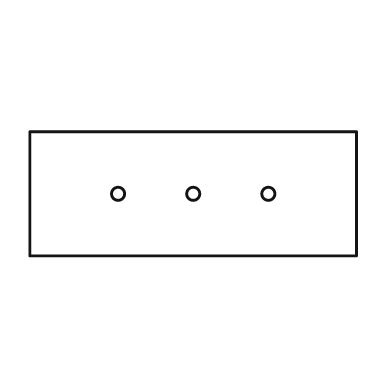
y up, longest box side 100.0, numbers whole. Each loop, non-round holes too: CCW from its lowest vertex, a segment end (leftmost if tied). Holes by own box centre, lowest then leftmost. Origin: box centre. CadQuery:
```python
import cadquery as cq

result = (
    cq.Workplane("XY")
    .moveTo(-50.0, -19.0)
    .lineTo(50.0, -19.0)
    .lineTo(50.0, 19.0)
    .lineTo(-50.0, 19.0)
    .close()
    .moveTo(-23.0, 0.0)
    .circle(2.0)
    .moveTo(0.0, 0.0)
    .circle(2.0)
    .moveTo(23.0, 0.0)
    .circle(2.0)
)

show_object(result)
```